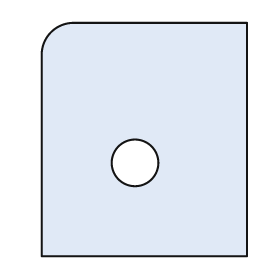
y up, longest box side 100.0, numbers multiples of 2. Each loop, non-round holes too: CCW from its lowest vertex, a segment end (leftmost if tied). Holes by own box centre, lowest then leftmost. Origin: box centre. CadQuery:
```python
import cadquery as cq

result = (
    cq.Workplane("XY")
    .moveTo(-44.0, -50.0)
    .lineTo(44.0, -50.0)
    .lineTo(44.0, 50.0)
    .lineTo(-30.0, 50.0)
    .threePointArc((-40.0, 46.0), (-44.0, 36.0))
    .close()
    .moveTo(-4.0, -10.0)
    .circle(10.0)
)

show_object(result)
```